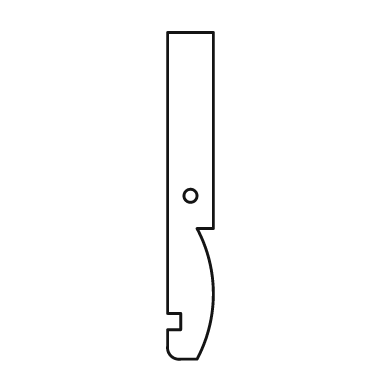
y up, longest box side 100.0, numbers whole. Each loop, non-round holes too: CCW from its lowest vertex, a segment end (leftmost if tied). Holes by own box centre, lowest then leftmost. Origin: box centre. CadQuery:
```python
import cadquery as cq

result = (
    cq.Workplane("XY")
    .moveTo(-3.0, -50.0)
    .lineTo(2.0, -50.0)
    .threePointArc((7.0, -30.0), (2.0, -10.0))
    .lineTo(7.0, -10.0)
    .lineTo(7.0, 50.0)
    .lineTo(-7.0, 50.0)
    .lineTo(-7.0, -36.0)
    .lineTo(-3.0, -36.0)
    .lineTo(-3.0, -41.0)
    .lineTo(-7.0, -41.0)
    .lineTo(-7.0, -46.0)
    .threePointArc((-6.0, -49.0), (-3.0, -50.0))
    .close()
    .moveTo(0.0, 0.0)
    .circle(2.0)
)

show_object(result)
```